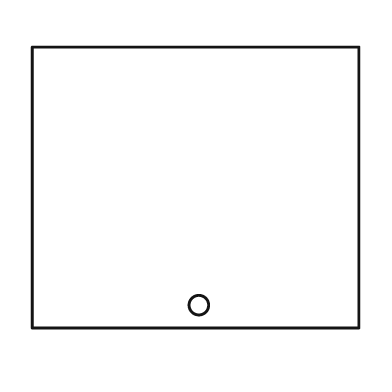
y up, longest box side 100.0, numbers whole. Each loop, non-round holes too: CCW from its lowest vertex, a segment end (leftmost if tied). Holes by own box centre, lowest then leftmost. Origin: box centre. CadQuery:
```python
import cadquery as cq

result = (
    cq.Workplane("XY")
    .moveTo(-50.0, -43.0)
    .lineTo(50.0, -43.0)
    .lineTo(50.0, 43.0)
    .lineTo(-50.0, 43.0)
    .close()
    .moveTo(1.0, -36.0)
    .circle(3.0)
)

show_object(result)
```